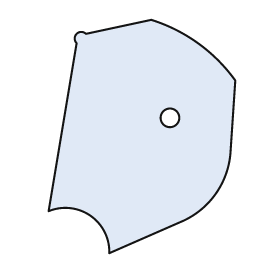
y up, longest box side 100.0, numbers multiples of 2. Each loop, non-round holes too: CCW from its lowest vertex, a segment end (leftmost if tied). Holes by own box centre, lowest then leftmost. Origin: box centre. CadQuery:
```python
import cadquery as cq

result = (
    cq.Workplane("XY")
    .moveTo(-14.0, -50.0)
    .lineTo(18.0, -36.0)
    .threePointArc((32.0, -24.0), (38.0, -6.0))
    .lineTo(40.0, 24.0)
    .threePointArc((24.0, 40.0), (4.0, 50.0))
    .lineTo(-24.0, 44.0)
    .threePointArc((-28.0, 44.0), (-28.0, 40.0))
    .lineTo(-40.0, -32.0)
    .threePointArc((-22.0, -34.0), (-14.0, -50.0))
    .close()
    .moveTo(12.0, 8.0)
    .circle(4.0)
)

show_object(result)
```